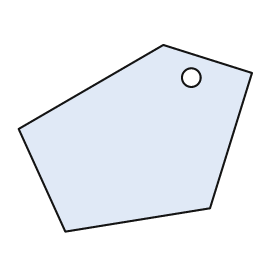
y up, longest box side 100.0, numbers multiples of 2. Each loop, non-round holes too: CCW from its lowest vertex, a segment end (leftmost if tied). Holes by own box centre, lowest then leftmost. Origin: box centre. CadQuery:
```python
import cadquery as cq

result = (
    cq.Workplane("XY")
    .moveTo(-30.0, -40.0)
    .lineTo(32.0, -30.0)
    .lineTo(50.0, 28.0)
    .lineTo(12.0, 40.0)
    .lineTo(-50.0, 4.0)
    .close()
    .moveTo(24.0, 26.0)
    .circle(4.0)
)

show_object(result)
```